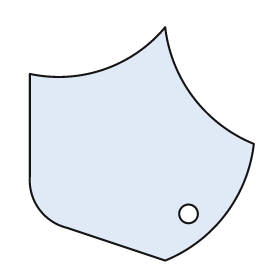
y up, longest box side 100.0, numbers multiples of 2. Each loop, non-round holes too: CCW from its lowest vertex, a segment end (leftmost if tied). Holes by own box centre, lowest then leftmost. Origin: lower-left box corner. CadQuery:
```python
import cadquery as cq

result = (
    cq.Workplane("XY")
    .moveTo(58.0, 0.0)
    .threePointArc((84.0, 20.0), (96.0, 50.0))
    .threePointArc((70.0, 70.0), (58.0, 100.0))
    .threePointArc((32.0, 82.0), (0.0, 80.0))
    .lineTo(0.0, 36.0)
    .threePointArc((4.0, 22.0), (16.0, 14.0))
    .close()
    .moveTo(68.0, 20.0)
    .circle(4.0)
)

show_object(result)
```